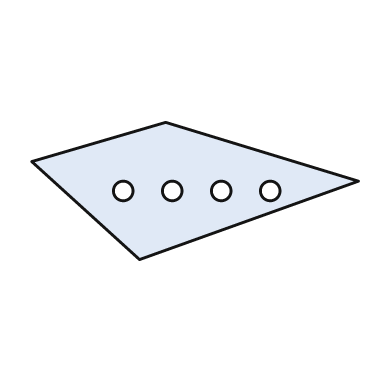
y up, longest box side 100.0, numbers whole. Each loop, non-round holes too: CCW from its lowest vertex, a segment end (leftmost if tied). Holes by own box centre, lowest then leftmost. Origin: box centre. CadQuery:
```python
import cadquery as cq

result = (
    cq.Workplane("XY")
    .moveTo(-17.0, -21.0)
    .lineTo(50.0, 3.0)
    .lineTo(-9.0, 21.0)
    .lineTo(-50.0, 9.0)
    .close()
    .moveTo(-22.0, 0.0)
    .circle(3.0)
    .moveTo(-7.0, 0.0)
    .circle(3.0)
    .moveTo(8.0, 0.0)
    .circle(3.0)
    .moveTo(23.0, 0.0)
    .circle(3.0)
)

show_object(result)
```